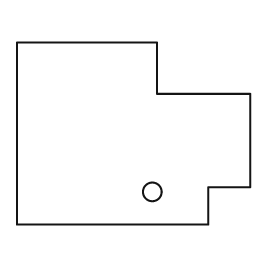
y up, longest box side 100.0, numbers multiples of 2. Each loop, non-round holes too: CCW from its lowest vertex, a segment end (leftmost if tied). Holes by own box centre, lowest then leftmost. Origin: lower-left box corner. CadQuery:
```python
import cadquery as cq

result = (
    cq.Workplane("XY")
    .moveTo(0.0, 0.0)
    .lineTo(82.0, 0.0)
    .lineTo(82.0, 16.0)
    .lineTo(100.0, 16.0)
    .lineTo(100.0, 56.0)
    .lineTo(60.0, 56.0)
    .lineTo(60.0, 78.0)
    .lineTo(0.0, 78.0)
    .close()
    .moveTo(58.0, 14.0)
    .circle(4.0)
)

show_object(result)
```